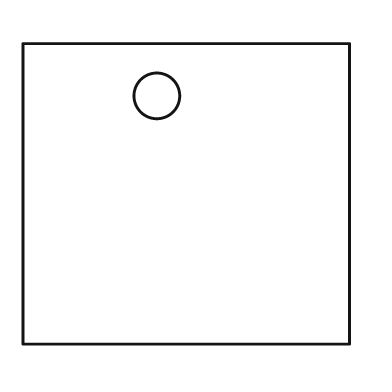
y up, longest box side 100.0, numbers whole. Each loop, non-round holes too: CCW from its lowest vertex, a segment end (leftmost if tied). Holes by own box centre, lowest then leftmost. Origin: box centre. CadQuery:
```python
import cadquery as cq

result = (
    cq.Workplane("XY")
    .moveTo(-50.0, -46.0)
    .lineTo(50.0, -46.0)
    .lineTo(50.0, 46.0)
    .lineTo(-50.0, 46.0)
    .close()
    .moveTo(-9.0, 30.0)
    .circle(7.0)
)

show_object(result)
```